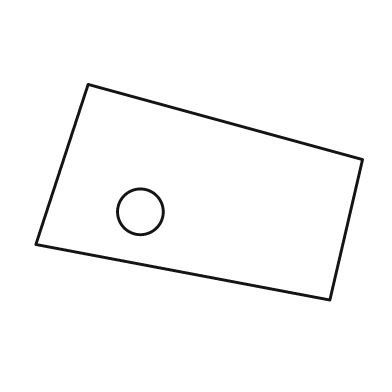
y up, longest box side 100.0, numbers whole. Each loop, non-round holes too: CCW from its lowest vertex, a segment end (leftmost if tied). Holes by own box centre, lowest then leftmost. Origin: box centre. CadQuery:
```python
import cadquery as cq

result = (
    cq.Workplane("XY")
    .moveTo(40.0, -33.0)
    .lineTo(50.0, 10.0)
    .lineTo(-34.0, 33.0)
    .lineTo(-50.0, -16.0)
    .close()
    .moveTo(-18.0, -6.0)
    .circle(7.0)
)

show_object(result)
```